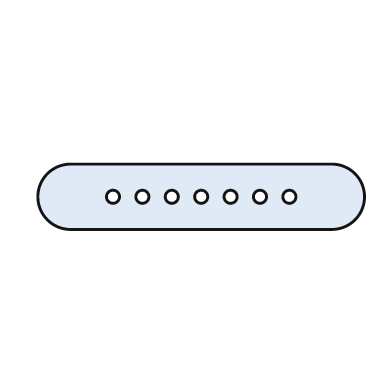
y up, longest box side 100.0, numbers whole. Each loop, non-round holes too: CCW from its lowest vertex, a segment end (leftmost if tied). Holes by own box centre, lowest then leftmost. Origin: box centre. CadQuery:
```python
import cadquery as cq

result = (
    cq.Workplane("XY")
    .moveTo(-40.0, -10.0)
    .lineTo(40.0, -10.0)
    .threePointArc((50.0, 0.0), (40.0, 10.0))
    .lineTo(-40.0, 10.0)
    .threePointArc((-50.0, 0.0), (-40.0, -10.0))
    .close()
    .moveTo(-27.0, 0.0)
    .circle(2.0)
    .moveTo(-18.0, 0.0)
    .circle(2.0)
    .moveTo(-9.0, 0.0)
    .circle(2.0)
    .moveTo(0.0, 0.0)
    .circle(2.0)
    .moveTo(9.0, 0.0)
    .circle(2.0)
    .moveTo(18.0, 0.0)
    .circle(2.0)
    .moveTo(27.0, 0.0)
    .circle(2.0)
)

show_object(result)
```